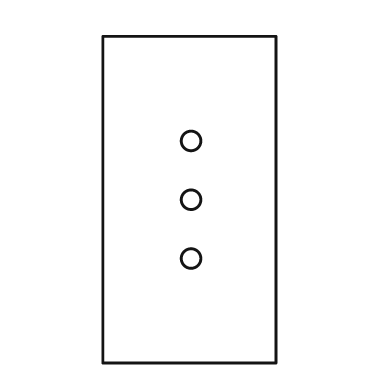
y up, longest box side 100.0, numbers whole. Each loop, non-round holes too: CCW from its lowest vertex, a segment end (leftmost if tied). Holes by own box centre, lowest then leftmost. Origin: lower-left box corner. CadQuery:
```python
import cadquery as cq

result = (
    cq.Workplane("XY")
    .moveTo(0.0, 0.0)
    .lineTo(53.0, 0.0)
    .lineTo(53.0, 100.0)
    .lineTo(0.0, 100.0)
    .close()
    .moveTo(27.0, 32.0)
    .circle(3.0)
    .moveTo(27.0, 50.0)
    .circle(3.0)
    .moveTo(27.0, 68.0)
    .circle(3.0)
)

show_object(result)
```